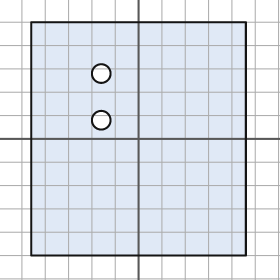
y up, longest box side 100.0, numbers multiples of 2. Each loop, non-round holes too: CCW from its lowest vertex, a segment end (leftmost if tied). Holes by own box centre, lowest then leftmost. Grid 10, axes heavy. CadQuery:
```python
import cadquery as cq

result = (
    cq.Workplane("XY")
    .moveTo(-46.0, -50.0)
    .lineTo(46.0, -50.0)
    .lineTo(46.0, 50.0)
    .lineTo(-46.0, 50.0)
    .close()
    .moveTo(-16.0, 8.0)
    .circle(4.0)
    .moveTo(-16.0, 28.0)
    .circle(4.0)
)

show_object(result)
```